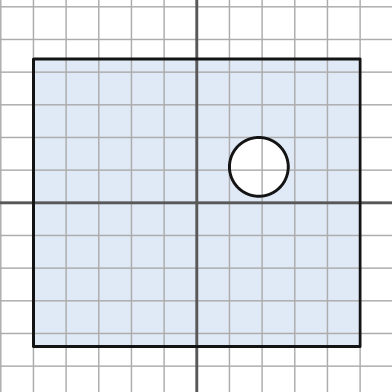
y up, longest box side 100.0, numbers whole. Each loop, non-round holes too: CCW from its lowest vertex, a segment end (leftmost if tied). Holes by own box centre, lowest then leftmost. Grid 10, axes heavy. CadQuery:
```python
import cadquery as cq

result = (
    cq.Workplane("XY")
    .moveTo(-50.0, -44.0)
    .lineTo(50.0, -44.0)
    .lineTo(50.0, 44.0)
    .lineTo(-50.0, 44.0)
    .close()
    .moveTo(19.0, 11.0)
    .circle(9.0)
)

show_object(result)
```